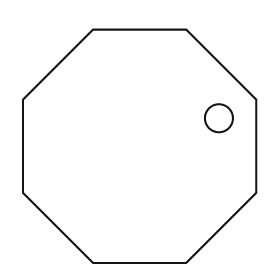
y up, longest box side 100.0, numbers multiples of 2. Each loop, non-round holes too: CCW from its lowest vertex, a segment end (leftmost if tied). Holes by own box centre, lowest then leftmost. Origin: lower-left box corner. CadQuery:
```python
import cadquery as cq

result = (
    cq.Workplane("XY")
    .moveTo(30.0, 0.0)
    .lineTo(70.0, 0.0)
    .lineTo(100.0, 30.0)
    .lineTo(100.0, 70.0)
    .lineTo(70.0, 100.0)
    .lineTo(30.0, 100.0)
    .lineTo(0.0, 70.0)
    .lineTo(0.0, 30.0)
    .close()
    .moveTo(84.0, 62.0)
    .circle(6.0)
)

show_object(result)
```